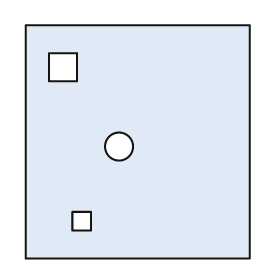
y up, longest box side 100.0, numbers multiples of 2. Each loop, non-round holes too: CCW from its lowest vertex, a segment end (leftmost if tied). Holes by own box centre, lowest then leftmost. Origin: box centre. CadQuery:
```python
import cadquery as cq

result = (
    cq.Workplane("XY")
    .moveTo(-48.0, -50.0)
    .lineTo(48.0, -50.0)
    .lineTo(48.0, 50.0)
    .lineTo(-48.0, 50.0)
    .close()
    .moveTo(-28.0, -38.0)
    .lineTo(-20.0, -38.0)
    .lineTo(-20.0, -30.0)
    .lineTo(-28.0, -30.0)
    .close()
    .moveTo(-8.0, -2.0)
    .circle(6.0)
    .moveTo(-38.0, 26.0)
    .lineTo(-26.0, 26.0)
    .lineTo(-26.0, 38.0)
    .lineTo(-38.0, 38.0)
    .close()
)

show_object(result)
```